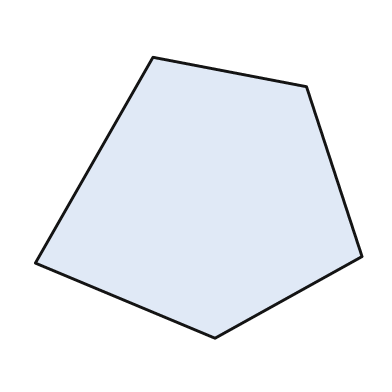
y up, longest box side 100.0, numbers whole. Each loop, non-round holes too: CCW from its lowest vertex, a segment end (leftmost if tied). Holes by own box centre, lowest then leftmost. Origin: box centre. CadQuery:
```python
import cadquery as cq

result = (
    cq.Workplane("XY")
    .moveTo(5.0, -43.0)
    .lineTo(50.0, -18.0)
    .lineTo(33.0, 34.0)
    .lineTo(-14.0, 43.0)
    .lineTo(-50.0, -20.0)
    .close()
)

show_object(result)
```